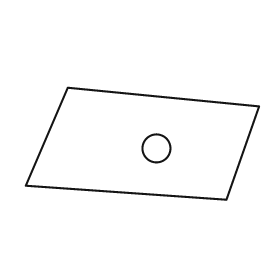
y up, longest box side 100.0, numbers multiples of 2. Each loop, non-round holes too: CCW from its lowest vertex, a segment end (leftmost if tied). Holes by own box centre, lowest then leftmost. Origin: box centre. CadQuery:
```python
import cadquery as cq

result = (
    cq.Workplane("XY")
    .moveTo(36.0, -24.0)
    .lineTo(50.0, 16.0)
    .lineTo(-32.0, 24.0)
    .lineTo(-50.0, -18.0)
    .close()
    .moveTo(6.0, -2.0)
    .circle(6.0)
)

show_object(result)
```